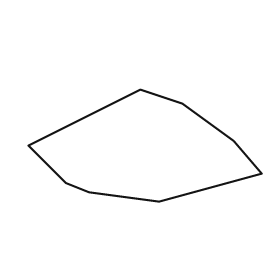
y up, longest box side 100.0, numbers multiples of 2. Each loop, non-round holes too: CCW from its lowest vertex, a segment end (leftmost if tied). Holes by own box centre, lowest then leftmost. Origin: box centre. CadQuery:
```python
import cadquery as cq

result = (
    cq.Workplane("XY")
    .moveTo(6.0, -24.0)
    .lineTo(50.0, -12.0)
    .lineTo(38.0, 2.0)
    .lineTo(16.0, 18.0)
    .lineTo(-2.0, 24.0)
    .lineTo(-50.0, 0.0)
    .lineTo(-34.0, -16.0)
    .lineTo(-24.0, -20.0)
    .close()
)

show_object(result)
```